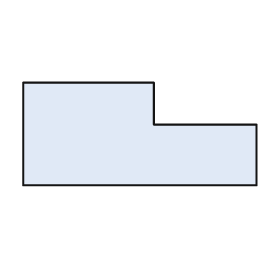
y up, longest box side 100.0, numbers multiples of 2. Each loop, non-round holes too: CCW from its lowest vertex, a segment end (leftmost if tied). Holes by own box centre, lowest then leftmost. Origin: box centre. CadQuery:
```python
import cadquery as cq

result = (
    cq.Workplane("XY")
    .moveTo(-50.0, -22.0)
    .lineTo(50.0, -22.0)
    .lineTo(50.0, 4.0)
    .lineTo(6.0, 4.0)
    .lineTo(6.0, 22.0)
    .lineTo(-50.0, 22.0)
    .close()
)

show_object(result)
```